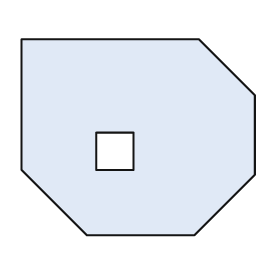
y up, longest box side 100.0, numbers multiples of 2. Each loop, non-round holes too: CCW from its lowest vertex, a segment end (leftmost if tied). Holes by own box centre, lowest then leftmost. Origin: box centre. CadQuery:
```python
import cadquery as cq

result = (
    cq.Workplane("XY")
    .moveTo(-22.0, -42.0)
    .lineTo(24.0, -42.0)
    .lineTo(50.0, -16.0)
    .lineTo(50.0, 18.0)
    .lineTo(26.0, 42.0)
    .lineTo(-50.0, 42.0)
    .lineTo(-50.0, -14.0)
    .close()
    .moveTo(-18.0, -14.0)
    .lineTo(-2.0, -14.0)
    .lineTo(-2.0, 2.0)
    .lineTo(-18.0, 2.0)
    .close()
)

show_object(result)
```